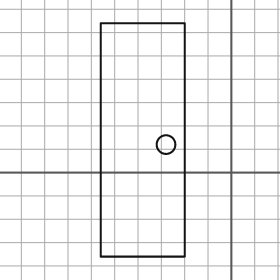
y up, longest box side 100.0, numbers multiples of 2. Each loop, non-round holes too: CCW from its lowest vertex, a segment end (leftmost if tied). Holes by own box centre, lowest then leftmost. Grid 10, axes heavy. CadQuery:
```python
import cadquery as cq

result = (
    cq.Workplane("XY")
    .moveTo(-56.0, -36.0)
    .lineTo(-20.0, -36.0)
    .lineTo(-20.0, 64.0)
    .lineTo(-56.0, 64.0)
    .close()
    .moveTo(-28.0, 12.0)
    .circle(4.0)
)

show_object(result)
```